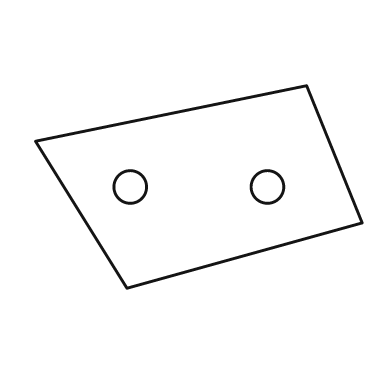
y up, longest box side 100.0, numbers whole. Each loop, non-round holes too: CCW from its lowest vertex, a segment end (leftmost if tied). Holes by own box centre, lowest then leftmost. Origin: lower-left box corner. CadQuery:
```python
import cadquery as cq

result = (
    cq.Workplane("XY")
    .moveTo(28.0, 0.0)
    .lineTo(100.0, 20.0)
    .lineTo(83.0, 62.0)
    .lineTo(0.0, 45.0)
    .close()
    .moveTo(29.0, 31.0)
    .circle(5.0)
    .moveTo(71.0, 31.0)
    .circle(5.0)
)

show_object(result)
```